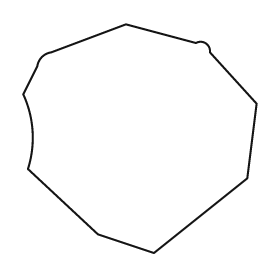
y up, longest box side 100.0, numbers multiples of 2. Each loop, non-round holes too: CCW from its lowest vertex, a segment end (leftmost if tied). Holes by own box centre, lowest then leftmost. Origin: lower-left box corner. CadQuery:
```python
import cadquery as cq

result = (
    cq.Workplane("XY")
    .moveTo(56.0, 0.0)
    .lineTo(96.0, 32.0)
    .lineTo(100.0, 64.0)
    .lineTo(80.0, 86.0)
    .threePointArc((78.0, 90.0), (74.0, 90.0))
    .lineTo(44.0, 98.0)
    .lineTo(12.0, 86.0)
    .threePointArc((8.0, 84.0), (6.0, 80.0))
    .lineTo(0.0, 68.0)
    .threePointArc((4.0, 52.0), (2.0, 36.0))
    .lineTo(32.0, 8.0)
    .close()
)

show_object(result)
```